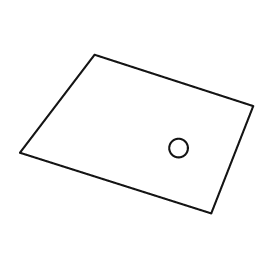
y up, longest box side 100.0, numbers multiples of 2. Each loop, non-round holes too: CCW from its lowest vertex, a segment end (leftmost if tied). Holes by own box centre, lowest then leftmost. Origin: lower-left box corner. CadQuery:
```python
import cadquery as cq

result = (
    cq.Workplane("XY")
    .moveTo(82.0, 0.0)
    .lineTo(100.0, 46.0)
    .lineTo(32.0, 68.0)
    .lineTo(0.0, 26.0)
    .close()
    .moveTo(68.0, 28.0)
    .circle(4.0)
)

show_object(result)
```